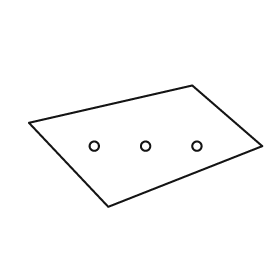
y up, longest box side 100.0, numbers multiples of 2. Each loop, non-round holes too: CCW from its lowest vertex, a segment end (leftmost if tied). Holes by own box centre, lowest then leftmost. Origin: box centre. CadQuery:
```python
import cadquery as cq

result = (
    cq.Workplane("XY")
    .moveTo(-16.0, -26.0)
    .lineTo(50.0, 0.0)
    .lineTo(20.0, 26.0)
    .lineTo(-50.0, 10.0)
    .close()
    .moveTo(-22.0, 0.0)
    .circle(2.0)
    .moveTo(0.0, 0.0)
    .circle(2.0)
    .moveTo(22.0, 0.0)
    .circle(2.0)
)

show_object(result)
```